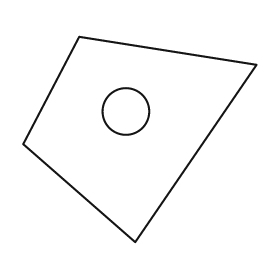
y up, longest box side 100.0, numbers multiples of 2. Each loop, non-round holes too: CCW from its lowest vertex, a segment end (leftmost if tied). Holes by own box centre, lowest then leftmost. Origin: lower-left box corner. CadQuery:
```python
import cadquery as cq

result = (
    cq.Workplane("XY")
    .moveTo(48.0, 0.0)
    .lineTo(100.0, 76.0)
    .lineTo(24.0, 88.0)
    .lineTo(0.0, 42.0)
    .close()
    .moveTo(44.0, 56.0)
    .circle(10.0)
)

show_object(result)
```